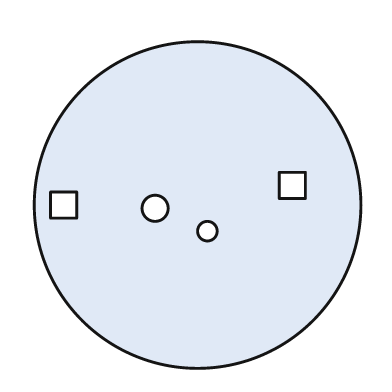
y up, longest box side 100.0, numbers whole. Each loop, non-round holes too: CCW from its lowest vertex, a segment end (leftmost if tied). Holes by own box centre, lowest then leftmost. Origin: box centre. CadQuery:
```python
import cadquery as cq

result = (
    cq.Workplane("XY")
    .moveTo(0.0, 0.0)
    .circle(50.0)
    .moveTo(3.0, -8.0)
    .circle(3.0)
    .moveTo(-13.0, -1.0)
    .circle(4.0)
    .moveTo(-45.0, -4.0)
    .lineTo(-37.0, -4.0)
    .lineTo(-37.0, 4.0)
    .lineTo(-45.0, 4.0)
    .close()
    .moveTo(25.0, 2.0)
    .lineTo(33.0, 2.0)
    .lineTo(33.0, 10.0)
    .lineTo(25.0, 10.0)
    .close()
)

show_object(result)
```